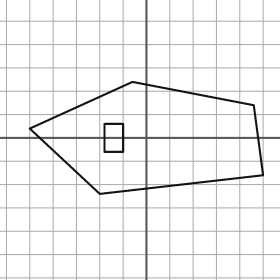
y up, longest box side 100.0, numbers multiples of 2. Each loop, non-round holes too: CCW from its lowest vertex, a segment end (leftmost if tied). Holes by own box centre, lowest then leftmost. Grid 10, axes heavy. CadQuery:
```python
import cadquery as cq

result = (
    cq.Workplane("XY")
    .moveTo(-20.0, -24.0)
    .lineTo(50.0, -16.0)
    .lineTo(46.0, 14.0)
    .lineTo(-6.0, 24.0)
    .lineTo(-50.0, 4.0)
    .close()
    .moveTo(-18.0, -6.0)
    .lineTo(-10.0, -6.0)
    .lineTo(-10.0, 6.0)
    .lineTo(-18.0, 6.0)
    .close()
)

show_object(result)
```